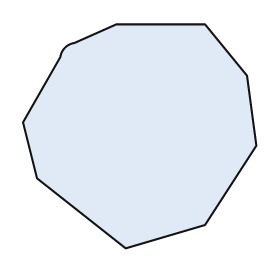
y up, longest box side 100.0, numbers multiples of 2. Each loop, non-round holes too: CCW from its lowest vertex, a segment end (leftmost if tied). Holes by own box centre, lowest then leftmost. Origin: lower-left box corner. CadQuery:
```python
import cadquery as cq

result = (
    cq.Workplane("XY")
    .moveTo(44.0, 0.0)
    .lineTo(78.0, 10.0)
    .lineTo(100.0, 44.0)
    .lineTo(96.0, 74.0)
    .lineTo(78.0, 96.0)
    .lineTo(40.0, 96.0)
    .lineTo(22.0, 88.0)
    .threePointArc((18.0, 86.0), (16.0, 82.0))
    .lineTo(0.0, 54.0)
    .lineTo(6.0, 30.0)
    .close()
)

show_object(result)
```